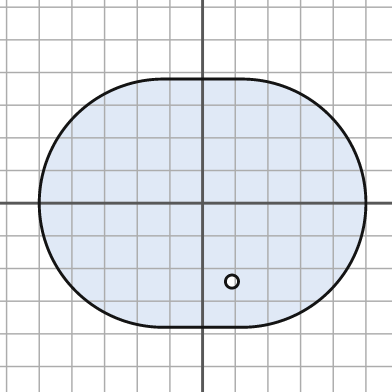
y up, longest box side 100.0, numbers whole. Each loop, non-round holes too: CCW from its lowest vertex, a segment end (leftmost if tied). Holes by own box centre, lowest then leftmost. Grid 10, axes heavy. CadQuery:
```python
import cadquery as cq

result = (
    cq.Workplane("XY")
    .moveTo(-12.0, -38.0)
    .lineTo(12.0, -38.0)
    .threePointArc((50.0, 0.0), (12.0, 38.0))
    .lineTo(-12.0, 38.0)
    .threePointArc((-50.0, 0.0), (-12.0, -38.0))
    .close()
    .moveTo(9.0, -24.0)
    .circle(2.0)
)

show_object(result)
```